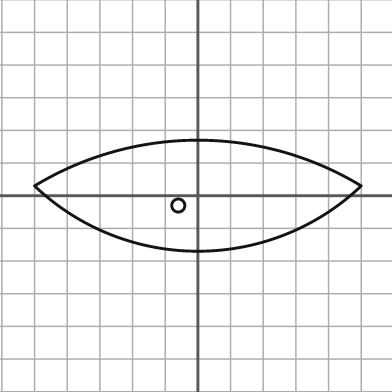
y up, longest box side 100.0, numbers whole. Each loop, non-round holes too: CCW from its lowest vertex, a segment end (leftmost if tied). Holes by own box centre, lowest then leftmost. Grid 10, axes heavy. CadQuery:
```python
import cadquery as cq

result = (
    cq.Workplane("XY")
    .moveTo(-50.0, 3.0)
    .threePointArc((0.0, -17.0), (50.0, 3.0))
    .threePointArc((0.0, 17.0), (-50.0, 3.0))
    .close()
    .moveTo(-6.0, -3.0)
    .circle(2.0)
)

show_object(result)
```